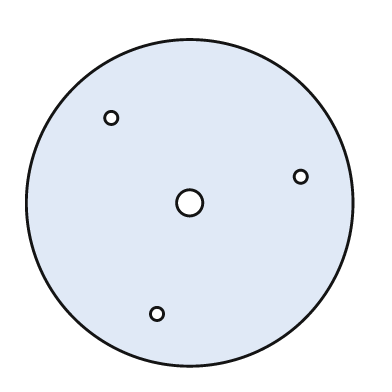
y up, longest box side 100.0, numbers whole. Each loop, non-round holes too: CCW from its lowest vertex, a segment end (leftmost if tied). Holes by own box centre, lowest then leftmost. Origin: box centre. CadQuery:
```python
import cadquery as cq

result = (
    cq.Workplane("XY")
    .moveTo(0.0, 0.0)
    .circle(50.0)
    .moveTo(-10.0, -34.0)
    .circle(2.0)
    .moveTo(0.0, 0.0)
    .circle(4.0)
    .moveTo(34.0, 8.0)
    .circle(2.0)
    .moveTo(-24.0, 26.0)
    .circle(2.0)
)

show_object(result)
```